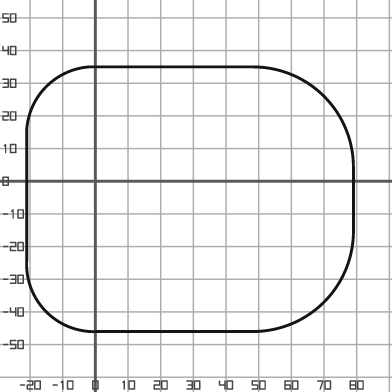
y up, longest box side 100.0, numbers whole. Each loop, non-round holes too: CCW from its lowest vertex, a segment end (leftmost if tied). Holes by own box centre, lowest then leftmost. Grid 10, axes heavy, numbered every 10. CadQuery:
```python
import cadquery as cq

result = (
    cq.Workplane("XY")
    .moveTo(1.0, -46.0)
    .lineTo(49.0, -46.0)
    .threePointArc((70.0, -37.0), (79.0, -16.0))
    .lineTo(79.0, 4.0)
    .threePointArc((70.0, 26.0), (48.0, 35.0))
    .lineTo(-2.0, 35.0)
    .threePointArc((-15.0, 29.0), (-21.0, 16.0))
    .lineTo(-21.0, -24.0)
    .threePointArc((-15.0, -40.0), (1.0, -46.0))
    .close()
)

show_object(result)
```